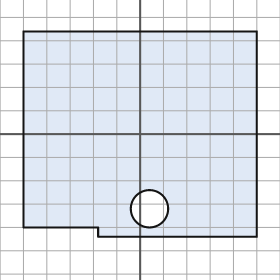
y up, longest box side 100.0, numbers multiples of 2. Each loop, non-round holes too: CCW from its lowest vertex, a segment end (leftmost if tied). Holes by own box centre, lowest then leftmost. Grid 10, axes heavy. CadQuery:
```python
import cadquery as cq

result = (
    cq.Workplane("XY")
    .moveTo(-18.0, -44.0)
    .lineTo(50.0, -44.0)
    .lineTo(50.0, 44.0)
    .lineTo(-50.0, 44.0)
    .lineTo(-50.0, -40.0)
    .lineTo(-18.0, -40.0)
    .close()
    .moveTo(4.0, -32.0)
    .circle(8.0)
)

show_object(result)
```